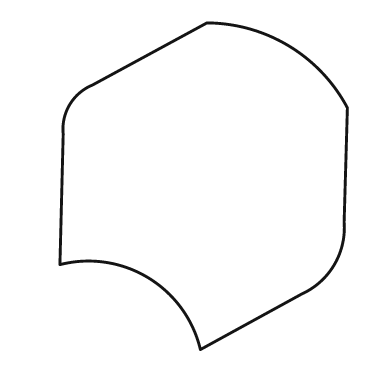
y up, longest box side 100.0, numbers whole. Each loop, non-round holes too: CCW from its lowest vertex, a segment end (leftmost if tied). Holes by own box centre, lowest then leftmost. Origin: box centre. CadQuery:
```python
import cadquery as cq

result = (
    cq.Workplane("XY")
    .moveTo(-1.0, -50.0)
    .lineTo(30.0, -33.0)
    .threePointArc((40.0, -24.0), (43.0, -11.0))
    .lineTo(44.0, 24.0)
    .threePointArc((26.0, 43.0), (1.0, 50.0))
    .lineTo(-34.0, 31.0)
    .threePointArc((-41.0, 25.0), (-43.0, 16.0))
    .lineTo(-44.0, -24.0)
    .threePointArc((-17.0, -28.0), (-1.0, -50.0))
    .close()
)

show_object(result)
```